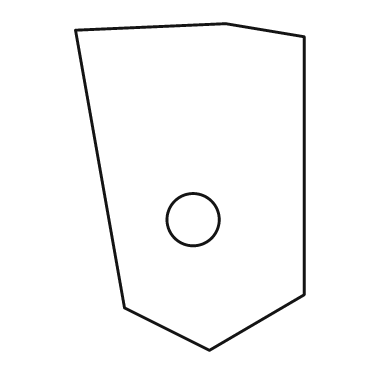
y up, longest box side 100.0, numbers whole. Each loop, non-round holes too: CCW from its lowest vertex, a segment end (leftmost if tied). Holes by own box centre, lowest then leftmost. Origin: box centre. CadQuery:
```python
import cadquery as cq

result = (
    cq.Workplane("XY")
    .moveTo(6.0, -50.0)
    .lineTo(35.0, -33.0)
    .lineTo(35.0, 46.0)
    .lineTo(11.0, 50.0)
    .lineTo(-35.0, 48.0)
    .lineTo(-20.0, -37.0)
    .close()
    .moveTo(1.0, -10.0)
    .circle(8.0)
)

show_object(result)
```